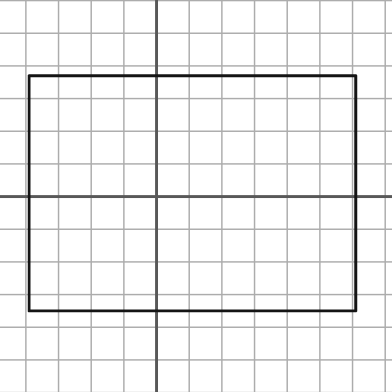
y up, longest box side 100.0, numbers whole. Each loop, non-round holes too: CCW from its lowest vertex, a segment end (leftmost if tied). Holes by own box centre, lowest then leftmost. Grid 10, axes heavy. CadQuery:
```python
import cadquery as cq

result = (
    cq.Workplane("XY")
    .moveTo(-39.0, -35.0)
    .lineTo(61.0, -35.0)
    .lineTo(61.0, 37.0)
    .lineTo(-39.0, 37.0)
    .close()
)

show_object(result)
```